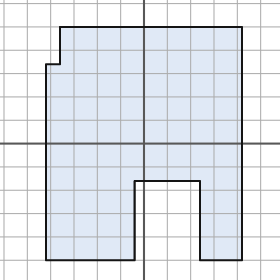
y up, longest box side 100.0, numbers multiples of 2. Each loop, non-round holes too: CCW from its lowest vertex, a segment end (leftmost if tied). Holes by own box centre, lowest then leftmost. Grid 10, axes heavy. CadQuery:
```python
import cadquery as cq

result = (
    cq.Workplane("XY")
    .moveTo(-42.0, -50.0)
    .lineTo(-4.0, -50.0)
    .lineTo(-4.0, -16.0)
    .lineTo(24.0, -16.0)
    .lineTo(24.0, -50.0)
    .lineTo(42.0, -50.0)
    .lineTo(42.0, 50.0)
    .lineTo(-36.0, 50.0)
    .lineTo(-36.0, 34.0)
    .lineTo(-42.0, 34.0)
    .close()
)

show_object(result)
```